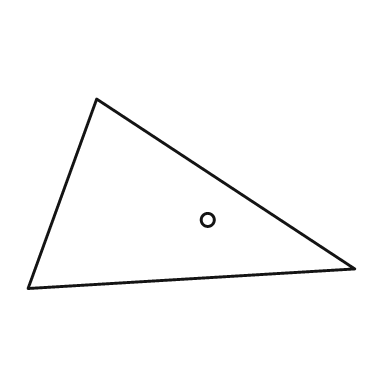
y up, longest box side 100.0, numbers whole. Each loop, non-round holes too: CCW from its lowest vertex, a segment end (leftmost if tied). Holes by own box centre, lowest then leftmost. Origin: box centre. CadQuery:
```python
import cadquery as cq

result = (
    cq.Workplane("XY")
    .moveTo(-50.0, -29.0)
    .lineTo(50.0, -23.0)
    .lineTo(-29.0, 29.0)
    .close()
    .moveTo(5.0, -8.0)
    .circle(2.0)
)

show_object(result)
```